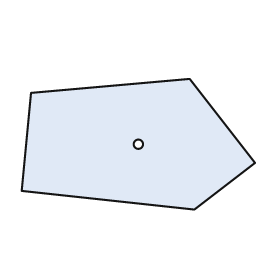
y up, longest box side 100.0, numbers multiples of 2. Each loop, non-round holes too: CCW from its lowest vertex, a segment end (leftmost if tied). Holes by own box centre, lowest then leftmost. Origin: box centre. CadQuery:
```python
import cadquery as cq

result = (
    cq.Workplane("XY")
    .moveTo(24.0, -28.0)
    .lineTo(50.0, -8.0)
    .lineTo(22.0, 28.0)
    .lineTo(-46.0, 22.0)
    .lineTo(-50.0, -20.0)
    .close()
    .moveTo(0.0, 0.0)
    .circle(2.0)
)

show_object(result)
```